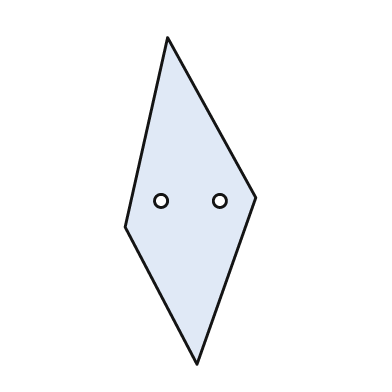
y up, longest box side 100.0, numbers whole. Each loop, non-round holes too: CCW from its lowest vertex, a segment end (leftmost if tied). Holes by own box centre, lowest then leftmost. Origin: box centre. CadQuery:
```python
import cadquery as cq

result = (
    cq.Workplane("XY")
    .moveTo(2.0, -50.0)
    .lineTo(20.0, 1.0)
    .lineTo(-7.0, 50.0)
    .lineTo(-20.0, -8.0)
    .close()
    .moveTo(-9.0, 0.0)
    .circle(2.0)
    .moveTo(9.0, 0.0)
    .circle(2.0)
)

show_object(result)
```